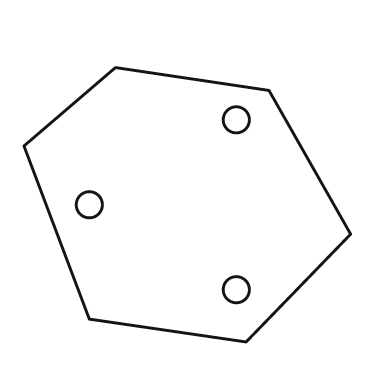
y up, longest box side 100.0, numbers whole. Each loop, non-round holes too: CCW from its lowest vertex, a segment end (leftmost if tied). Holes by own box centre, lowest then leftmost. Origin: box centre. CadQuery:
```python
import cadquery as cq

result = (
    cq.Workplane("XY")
    .moveTo(18.0, -42.0)
    .lineTo(50.0, -9.0)
    .lineTo(25.0, 35.0)
    .lineTo(-22.0, 42.0)
    .lineTo(-50.0, 18.0)
    .lineTo(-30.0, -35.0)
    .close()
    .moveTo(15.0, -26.0)
    .circle(4.0)
    .moveTo(-30.0, 0.0)
    .circle(4.0)
    .moveTo(15.0, 26.0)
    .circle(4.0)
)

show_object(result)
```